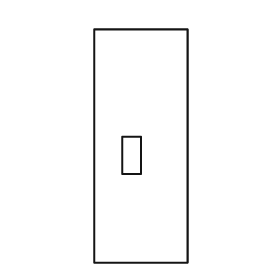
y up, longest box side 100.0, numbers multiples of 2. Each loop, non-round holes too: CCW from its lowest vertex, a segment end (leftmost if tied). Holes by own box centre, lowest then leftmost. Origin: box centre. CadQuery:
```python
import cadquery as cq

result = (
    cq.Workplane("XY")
    .moveTo(-20.0, -50.0)
    .lineTo(20.0, -50.0)
    .lineTo(20.0, 50.0)
    .lineTo(-20.0, 50.0)
    .close()
    .moveTo(-8.0, -12.0)
    .lineTo(0.0, -12.0)
    .lineTo(0.0, 4.0)
    .lineTo(-8.0, 4.0)
    .close()
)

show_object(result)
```